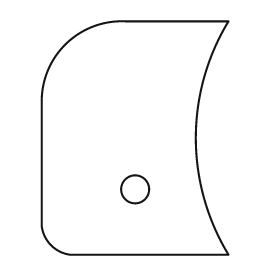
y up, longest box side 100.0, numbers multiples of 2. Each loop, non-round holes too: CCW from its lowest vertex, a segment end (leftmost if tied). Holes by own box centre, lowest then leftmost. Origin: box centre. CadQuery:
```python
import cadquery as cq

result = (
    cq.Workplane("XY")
    .moveTo(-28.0, -50.0)
    .lineTo(40.0, -50.0)
    .threePointArc((26.0, 0.0), (40.0, 50.0))
    .lineTo(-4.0, 50.0)
    .threePointArc((-30.0, 40.0), (-40.0, 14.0))
    .lineTo(-40.0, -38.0)
    .threePointArc((-36.0, -46.0), (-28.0, -50.0))
    .close()
    .moveTo(0.0, -22.0)
    .circle(6.0)
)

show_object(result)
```